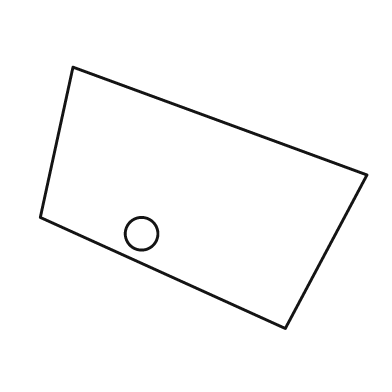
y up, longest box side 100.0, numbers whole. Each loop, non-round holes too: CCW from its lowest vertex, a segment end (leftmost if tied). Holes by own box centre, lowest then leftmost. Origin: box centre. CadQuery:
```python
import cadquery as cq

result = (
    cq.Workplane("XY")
    .moveTo(25.0, -40.0)
    .lineTo(50.0, 7.0)
    .lineTo(-40.0, 40.0)
    .lineTo(-50.0, -6.0)
    .close()
    .moveTo(-19.0, -11.0)
    .circle(5.0)
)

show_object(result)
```